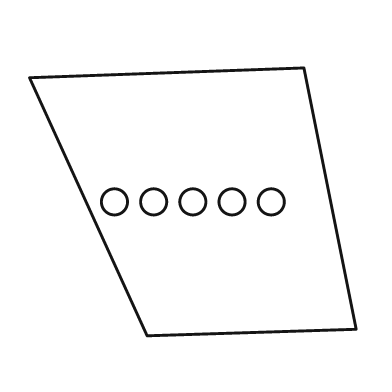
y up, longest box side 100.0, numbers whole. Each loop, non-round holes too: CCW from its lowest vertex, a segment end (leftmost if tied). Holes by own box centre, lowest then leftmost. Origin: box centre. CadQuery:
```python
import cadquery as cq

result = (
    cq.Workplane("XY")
    .moveTo(-14.0, -41.0)
    .lineTo(50.0, -39.0)
    .lineTo(34.0, 41.0)
    .lineTo(-50.0, 38.0)
    .close()
    .moveTo(-24.0, 0.0)
    .circle(4.0)
    .moveTo(-12.0, 0.0)
    .circle(4.0)
    .moveTo(0.0, 0.0)
    .circle(4.0)
    .moveTo(12.0, 0.0)
    .circle(4.0)
    .moveTo(24.0, 0.0)
    .circle(4.0)
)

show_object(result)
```